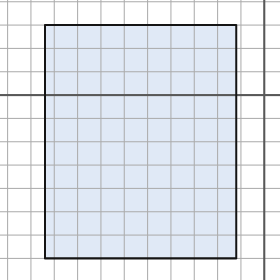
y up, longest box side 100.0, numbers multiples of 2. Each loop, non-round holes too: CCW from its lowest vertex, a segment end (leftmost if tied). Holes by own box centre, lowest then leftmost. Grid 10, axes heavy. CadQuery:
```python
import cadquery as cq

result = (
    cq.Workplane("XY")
    .moveTo(-94.0, -70.0)
    .lineTo(-12.0, -70.0)
    .lineTo(-12.0, 30.0)
    .lineTo(-94.0, 30.0)
    .close()
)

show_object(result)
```